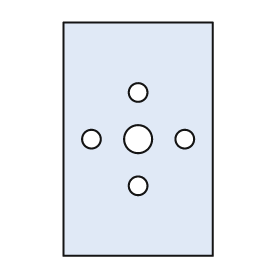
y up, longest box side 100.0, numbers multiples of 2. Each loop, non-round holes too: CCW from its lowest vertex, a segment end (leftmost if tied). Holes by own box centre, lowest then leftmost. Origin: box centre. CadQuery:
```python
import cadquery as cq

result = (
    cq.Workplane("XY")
    .moveTo(-32.0, -50.0)
    .lineTo(32.0, -50.0)
    .lineTo(32.0, 50.0)
    .lineTo(-32.0, 50.0)
    .close()
    .moveTo(0.0, -20.0)
    .circle(4.0)
    .moveTo(-20.0, 0.0)
    .circle(4.0)
    .moveTo(0.0, 0.0)
    .circle(6.0)
    .moveTo(20.0, 0.0)
    .circle(4.0)
    .moveTo(0.0, 20.0)
    .circle(4.0)
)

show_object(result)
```